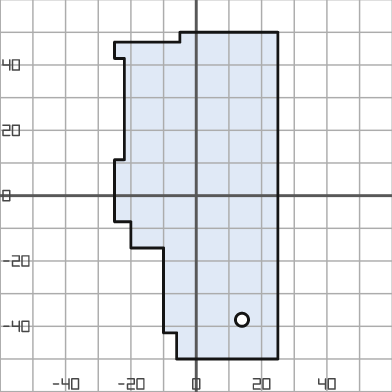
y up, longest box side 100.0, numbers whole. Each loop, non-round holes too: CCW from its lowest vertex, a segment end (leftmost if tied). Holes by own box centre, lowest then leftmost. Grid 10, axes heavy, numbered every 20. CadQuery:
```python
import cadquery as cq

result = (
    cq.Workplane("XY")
    .moveTo(-6.0, -50.0)
    .lineTo(25.0, -50.0)
    .lineTo(25.0, 50.0)
    .lineTo(-5.0, 50.0)
    .lineTo(-5.0, 47.0)
    .lineTo(-25.0, 47.0)
    .lineTo(-25.0, 42.0)
    .lineTo(-22.0, 42.0)
    .lineTo(-22.0, 11.0)
    .lineTo(-25.0, 11.0)
    .lineTo(-25.0, -8.0)
    .lineTo(-20.0, -8.0)
    .lineTo(-20.0, -16.0)
    .lineTo(-10.0, -16.0)
    .lineTo(-10.0, -42.0)
    .lineTo(-6.0, -42.0)
    .close()
    .moveTo(14.0, -38.0)
    .circle(2.0)
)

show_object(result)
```